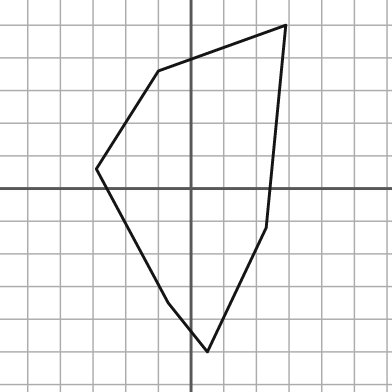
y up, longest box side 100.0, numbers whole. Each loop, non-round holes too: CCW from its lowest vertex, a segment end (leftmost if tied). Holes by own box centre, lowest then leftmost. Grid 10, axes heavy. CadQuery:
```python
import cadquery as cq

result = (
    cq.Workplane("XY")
    .moveTo(5.0, -50.0)
    .lineTo(23.0, -12.0)
    .lineTo(29.0, 50.0)
    .lineTo(-10.0, 36.0)
    .lineTo(-29.0, 6.0)
    .lineTo(-7.0, -35.0)
    .close()
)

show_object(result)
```